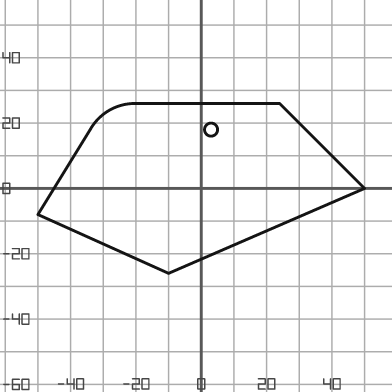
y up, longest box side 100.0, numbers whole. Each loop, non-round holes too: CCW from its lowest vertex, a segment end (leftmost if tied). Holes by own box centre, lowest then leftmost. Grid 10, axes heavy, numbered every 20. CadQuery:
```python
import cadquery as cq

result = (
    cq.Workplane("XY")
    .moveTo(-10.0, -26.0)
    .lineTo(50.0, 0.0)
    .lineTo(24.0, 26.0)
    .lineTo(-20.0, 26.0)
    .threePointArc((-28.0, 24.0), (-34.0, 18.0))
    .lineTo(-50.0, -8.0)
    .close()
    .moveTo(3.0, 18.0)
    .circle(2.0)
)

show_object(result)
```